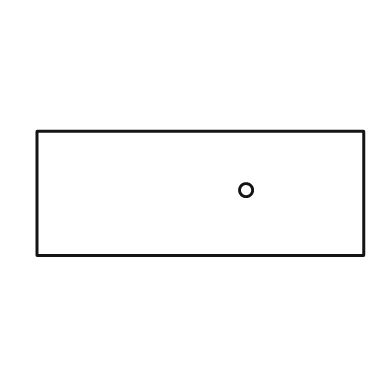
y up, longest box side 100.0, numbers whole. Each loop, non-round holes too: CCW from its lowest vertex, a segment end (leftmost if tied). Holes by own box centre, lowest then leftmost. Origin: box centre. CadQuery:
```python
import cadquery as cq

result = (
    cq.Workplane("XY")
    .moveTo(-50.0, -19.0)
    .lineTo(50.0, -19.0)
    .lineTo(50.0, 19.0)
    .lineTo(-50.0, 19.0)
    .close()
    .moveTo(14.0, 1.0)
    .circle(2.0)
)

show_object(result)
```